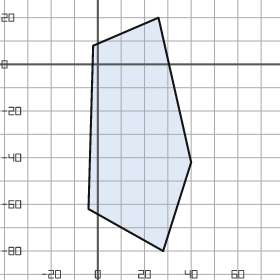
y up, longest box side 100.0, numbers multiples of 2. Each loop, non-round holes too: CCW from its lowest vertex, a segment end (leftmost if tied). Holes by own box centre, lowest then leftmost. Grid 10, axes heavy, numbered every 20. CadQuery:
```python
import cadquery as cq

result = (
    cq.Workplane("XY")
    .moveTo(28.0, -80.0)
    .lineTo(40.0, -42.0)
    .lineTo(26.0, 20.0)
    .lineTo(-2.0, 8.0)
    .lineTo(-4.0, -62.0)
    .close()
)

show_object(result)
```